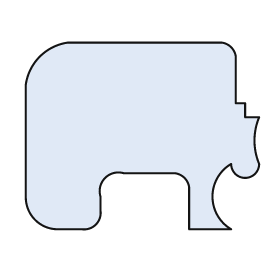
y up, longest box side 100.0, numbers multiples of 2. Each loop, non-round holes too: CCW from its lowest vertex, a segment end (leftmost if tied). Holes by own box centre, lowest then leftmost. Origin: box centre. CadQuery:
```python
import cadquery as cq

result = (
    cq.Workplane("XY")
    .moveTo(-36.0, -40.0)
    .lineTo(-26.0, -40.0)
    .threePointArc((-20.0, -38.0), (-18.0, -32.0))
    .lineTo(-18.0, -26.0)
    .threePointArc((-16.0, -18.0), (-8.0, -16.0))
    .lineTo(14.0, -16.0)
    .threePointArc((18.0, -18.0), (20.0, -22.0))
    .lineTo(20.0, -40.0)
    .lineTo(38.0, -40.0)
    .threePointArc((30.0, -26.0), (38.0, -12.0))
    .threePointArc((44.0, -18.0), (50.0, -12.0))
    .threePointArc((48.0, -2.0), (50.0, 8.0))
    .lineTo(44.0, 8.0)
    .lineTo(44.0, 14.0)
    .lineTo(40.0, 14.0)
    .lineTo(40.0, 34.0)
    .threePointArc((38.0, 38.0), (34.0, 40.0))
    .lineTo(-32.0, 40.0)
    .threePointArc((-44.0, 34.0), (-50.0, 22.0))
    .lineTo(-50.0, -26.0)
    .threePointArc((-46.0, -36.0), (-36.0, -40.0))
    .close()
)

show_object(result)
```